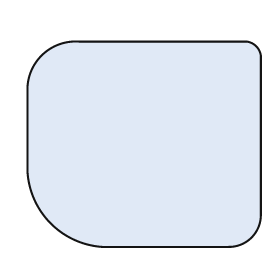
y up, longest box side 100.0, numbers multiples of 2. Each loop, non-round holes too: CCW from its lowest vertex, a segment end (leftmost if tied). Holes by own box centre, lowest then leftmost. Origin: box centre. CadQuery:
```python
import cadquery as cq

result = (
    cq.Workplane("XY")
    .moveTo(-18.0, -44.0)
    .lineTo(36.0, -44.0)
    .threePointArc((46.0, -40.0), (50.0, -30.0))
    .lineTo(50.0, 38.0)
    .threePointArc((48.0, 42.0), (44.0, 44.0))
    .lineTo(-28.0, 44.0)
    .threePointArc((-44.0, 38.0), (-50.0, 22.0))
    .lineTo(-50.0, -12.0)
    .threePointArc((-40.0, -34.0), (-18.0, -44.0))
    .close()
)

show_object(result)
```